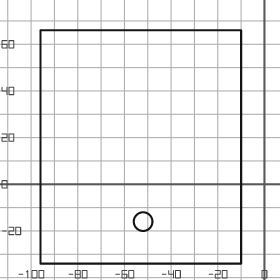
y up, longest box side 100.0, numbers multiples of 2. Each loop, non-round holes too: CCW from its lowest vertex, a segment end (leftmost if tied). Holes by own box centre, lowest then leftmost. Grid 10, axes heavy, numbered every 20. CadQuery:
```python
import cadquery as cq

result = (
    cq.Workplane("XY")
    .moveTo(-96.0, -34.0)
    .lineTo(-10.0, -34.0)
    .lineTo(-10.0, 66.0)
    .lineTo(-96.0, 66.0)
    .close()
    .moveTo(-52.0, -16.0)
    .circle(4.0)
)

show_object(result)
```